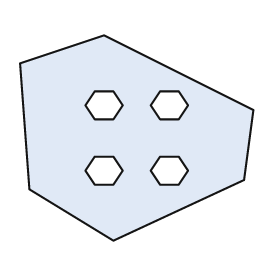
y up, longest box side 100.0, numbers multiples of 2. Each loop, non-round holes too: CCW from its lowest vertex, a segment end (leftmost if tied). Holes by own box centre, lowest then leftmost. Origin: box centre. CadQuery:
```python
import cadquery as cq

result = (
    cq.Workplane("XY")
    .moveTo(-10.0, -44.0)
    .lineTo(46.0, -18.0)
    .lineTo(50.0, 12.0)
    .lineTo(-14.0, 44.0)
    .lineTo(-50.0, 32.0)
    .lineTo(-46.0, -22.0)
    .close()
    .moveTo(-18.0, -20.0)
    .lineTo(-10.0, -20.0)
    .lineTo(-6.0, -14.0)
    .lineTo(-10.0, -8.0)
    .lineTo(-18.0, -8.0)
    .lineTo(-22.0, -14.0)
    .close()
    .moveTo(10.0, -20.0)
    .lineTo(18.0, -20.0)
    .lineTo(22.0, -14.0)
    .lineTo(18.0, -8.0)
    .lineTo(10.0, -8.0)
    .lineTo(6.0, -14.0)
    .close()
    .moveTo(-18.0, 8.0)
    .lineTo(-10.0, 8.0)
    .lineTo(-6.0, 14.0)
    .lineTo(-10.0, 20.0)
    .lineTo(-18.0, 20.0)
    .lineTo(-22.0, 14.0)
    .close()
    .moveTo(10.0, 8.0)
    .lineTo(18.0, 8.0)
    .lineTo(22.0, 14.0)
    .lineTo(18.0, 20.0)
    .lineTo(10.0, 20.0)
    .lineTo(6.0, 14.0)
    .close()
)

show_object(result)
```